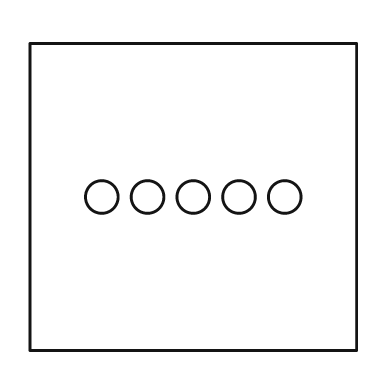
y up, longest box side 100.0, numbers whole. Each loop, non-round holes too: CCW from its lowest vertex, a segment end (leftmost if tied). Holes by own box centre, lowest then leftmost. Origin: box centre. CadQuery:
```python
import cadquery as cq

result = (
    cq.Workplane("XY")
    .moveTo(-50.0, -47.0)
    .lineTo(50.0, -47.0)
    .lineTo(50.0, 47.0)
    .lineTo(-50.0, 47.0)
    .close()
    .moveTo(-28.0, 0.0)
    .circle(5.0)
    .moveTo(-14.0, 0.0)
    .circle(5.0)
    .moveTo(0.0, 0.0)
    .circle(5.0)
    .moveTo(14.0, 0.0)
    .circle(5.0)
    .moveTo(28.0, 0.0)
    .circle(5.0)
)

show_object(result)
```